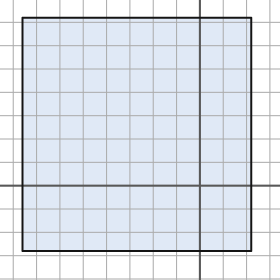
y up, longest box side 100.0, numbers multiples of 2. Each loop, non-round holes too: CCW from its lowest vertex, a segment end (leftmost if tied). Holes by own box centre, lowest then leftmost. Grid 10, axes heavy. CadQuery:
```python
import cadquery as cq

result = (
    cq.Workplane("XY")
    .moveTo(-76.0, -28.0)
    .lineTo(22.0, -28.0)
    .lineTo(22.0, 72.0)
    .lineTo(-76.0, 72.0)
    .close()
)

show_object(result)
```